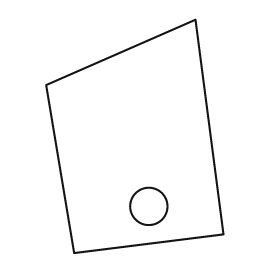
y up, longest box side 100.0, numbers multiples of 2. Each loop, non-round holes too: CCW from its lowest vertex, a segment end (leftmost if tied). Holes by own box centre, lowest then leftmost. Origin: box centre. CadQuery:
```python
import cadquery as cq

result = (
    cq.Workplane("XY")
    .moveTo(-26.0, -50.0)
    .lineTo(38.0, -42.0)
    .lineTo(26.0, 50.0)
    .lineTo(-38.0, 22.0)
    .close()
    .moveTo(6.0, -30.0)
    .circle(8.0)
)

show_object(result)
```